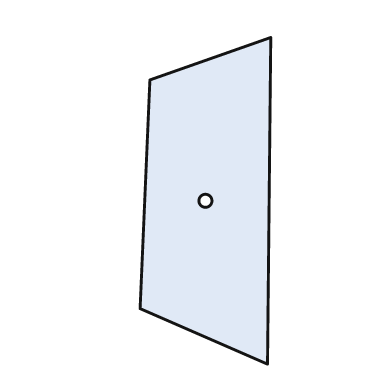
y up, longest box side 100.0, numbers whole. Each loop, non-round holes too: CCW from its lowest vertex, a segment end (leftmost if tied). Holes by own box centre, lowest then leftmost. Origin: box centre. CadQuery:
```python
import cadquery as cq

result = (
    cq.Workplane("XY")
    .moveTo(19.0, -50.0)
    .lineTo(20.0, 50.0)
    .lineTo(-17.0, 37.0)
    .lineTo(-20.0, -33.0)
    .close()
    .moveTo(0.0, 0.0)
    .circle(2.0)
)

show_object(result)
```